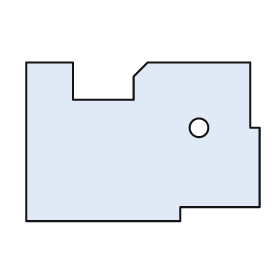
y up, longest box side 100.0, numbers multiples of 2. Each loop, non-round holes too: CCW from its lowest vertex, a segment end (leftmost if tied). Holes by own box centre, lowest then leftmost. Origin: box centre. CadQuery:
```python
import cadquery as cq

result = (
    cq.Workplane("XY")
    .moveTo(-50.0, -34.0)
    .lineTo(16.0, -34.0)
    .lineTo(16.0, -28.0)
    .lineTo(50.0, -28.0)
    .lineTo(50.0, 6.0)
    .lineTo(46.0, 6.0)
    .lineTo(46.0, 34.0)
    .lineTo(2.0, 34.0)
    .lineTo(-4.0, 28.0)
    .lineTo(-4.0, 18.0)
    .lineTo(-30.0, 18.0)
    .lineTo(-30.0, 34.0)
    .lineTo(-50.0, 34.0)
    .close()
    .moveTo(24.0, 6.0)
    .circle(4.0)
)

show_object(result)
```